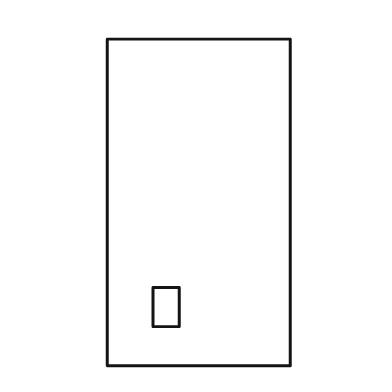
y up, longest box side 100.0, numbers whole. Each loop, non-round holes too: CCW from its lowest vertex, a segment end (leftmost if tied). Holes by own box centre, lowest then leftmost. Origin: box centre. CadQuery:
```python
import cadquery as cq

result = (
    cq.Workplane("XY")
    .moveTo(-28.0, -50.0)
    .lineTo(28.0, -50.0)
    .lineTo(28.0, 50.0)
    .lineTo(-28.0, 50.0)
    .close()
    .moveTo(-14.0, -38.0)
    .lineTo(-6.0, -38.0)
    .lineTo(-6.0, -26.0)
    .lineTo(-14.0, -26.0)
    .close()
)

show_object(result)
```